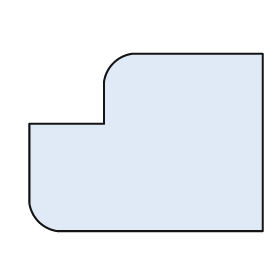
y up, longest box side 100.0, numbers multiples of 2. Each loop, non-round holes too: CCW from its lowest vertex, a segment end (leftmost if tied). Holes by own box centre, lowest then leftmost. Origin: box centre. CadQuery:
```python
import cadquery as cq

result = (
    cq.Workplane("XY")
    .moveTo(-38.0, -38.0)
    .lineTo(50.0, -38.0)
    .lineTo(50.0, 38.0)
    .lineTo(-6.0, 38.0)
    .threePointArc((-14.0, 34.0), (-18.0, 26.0))
    .lineTo(-18.0, 8.0)
    .lineTo(-50.0, 8.0)
    .lineTo(-50.0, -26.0)
    .threePointArc((-46.0, -34.0), (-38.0, -38.0))
    .close()
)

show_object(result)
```